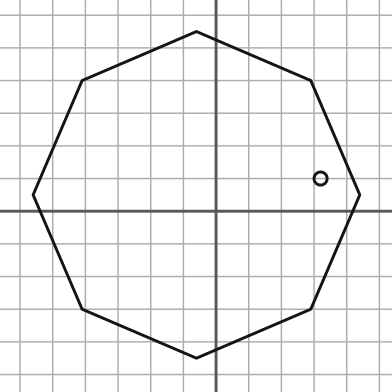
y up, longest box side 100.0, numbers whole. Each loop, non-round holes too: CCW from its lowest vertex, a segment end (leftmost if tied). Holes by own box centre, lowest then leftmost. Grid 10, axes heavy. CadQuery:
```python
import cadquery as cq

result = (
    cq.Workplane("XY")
    .moveTo(-6.0, -45.0)
    .lineTo(29.0, -30.0)
    .lineTo(44.0, 5.0)
    .lineTo(29.0, 40.0)
    .lineTo(-6.0, 55.0)
    .lineTo(-41.0, 40.0)
    .lineTo(-56.0, 5.0)
    .lineTo(-41.0, -30.0)
    .close()
    .moveTo(32.0, 10.0)
    .circle(2.0)
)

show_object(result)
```